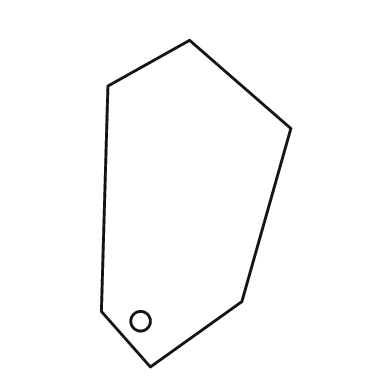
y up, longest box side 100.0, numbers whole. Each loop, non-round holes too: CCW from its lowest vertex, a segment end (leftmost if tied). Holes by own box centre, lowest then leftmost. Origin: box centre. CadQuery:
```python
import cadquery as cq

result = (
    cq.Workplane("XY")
    .moveTo(-14.0, -50.0)
    .lineTo(14.0, -30.0)
    .lineTo(29.0, 23.0)
    .lineTo(-2.0, 50.0)
    .lineTo(-27.0, 36.0)
    .lineTo(-29.0, -33.0)
    .close()
    .moveTo(-17.0, -36.0)
    .circle(3.0)
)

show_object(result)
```